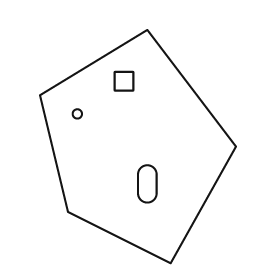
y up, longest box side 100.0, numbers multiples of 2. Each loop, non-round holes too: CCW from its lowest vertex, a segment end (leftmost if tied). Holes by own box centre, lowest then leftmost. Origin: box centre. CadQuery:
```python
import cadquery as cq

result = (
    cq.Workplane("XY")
    .moveTo(14.0, -50.0)
    .lineTo(42.0, 0.0)
    .lineTo(4.0, 50.0)
    .lineTo(-42.0, 22.0)
    .lineTo(-30.0, -28.0)
    .close()
    .moveTo(0.0, -20.0)
    .threePointArc((4.0, -24.0), (8.0, -20.0))
    .lineTo(8.0, -12.0)
    .threePointArc((4.0, -8.0), (0.0, -12.0))
    .close()
    .moveTo(-26.0, 14.0)
    .circle(2.0)
    .moveTo(-10.0, 24.0)
    .lineTo(-2.0, 24.0)
    .lineTo(-2.0, 32.0)
    .lineTo(-10.0, 32.0)
    .close()
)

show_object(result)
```